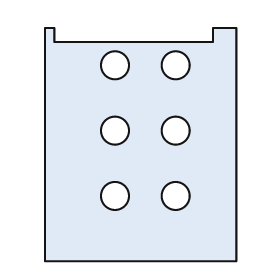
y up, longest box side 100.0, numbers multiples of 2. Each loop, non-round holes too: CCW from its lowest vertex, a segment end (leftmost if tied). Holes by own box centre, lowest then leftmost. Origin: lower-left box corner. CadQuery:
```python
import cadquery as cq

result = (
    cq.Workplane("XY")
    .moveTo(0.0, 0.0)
    .lineTo(82.0, 0.0)
    .lineTo(82.0, 100.0)
    .lineTo(72.0, 100.0)
    .lineTo(72.0, 94.0)
    .lineTo(4.0, 94.0)
    .lineTo(4.0, 100.0)
    .lineTo(0.0, 100.0)
    .close()
    .moveTo(30.0, 28.0)
    .circle(6.0)
    .moveTo(56.0, 28.0)
    .circle(6.0)
    .moveTo(30.0, 56.0)
    .circle(6.0)
    .moveTo(56.0, 56.0)
    .circle(6.0)
    .moveTo(30.0, 84.0)
    .circle(6.0)
    .moveTo(56.0, 84.0)
    .circle(6.0)
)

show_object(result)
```